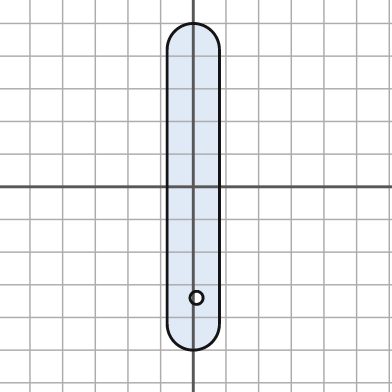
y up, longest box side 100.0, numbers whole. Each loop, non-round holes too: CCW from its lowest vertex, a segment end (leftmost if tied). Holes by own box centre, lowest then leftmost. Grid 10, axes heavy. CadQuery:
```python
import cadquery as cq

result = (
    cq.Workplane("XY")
    .moveTo(-8.0, -42.0)
    .threePointArc((0.0, -50.0), (8.0, -42.0))
    .lineTo(8.0, 42.0)
    .threePointArc((0.0, 50.0), (-8.0, 42.0))
    .close()
    .moveTo(1.0, -34.0)
    .circle(2.0)
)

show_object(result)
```